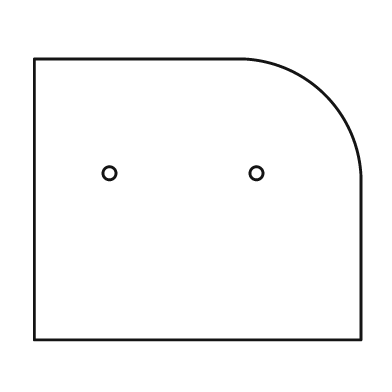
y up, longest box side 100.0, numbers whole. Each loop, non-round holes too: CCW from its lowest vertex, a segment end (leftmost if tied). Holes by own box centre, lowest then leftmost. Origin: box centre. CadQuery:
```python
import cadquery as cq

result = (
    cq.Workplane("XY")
    .moveTo(-50.0, -43.0)
    .lineTo(50.0, -43.0)
    .lineTo(50.0, 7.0)
    .threePointArc((39.0, 32.0), (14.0, 43.0))
    .lineTo(-50.0, 43.0)
    .close()
    .moveTo(-27.0, 8.0)
    .circle(2.0)
    .moveTo(18.0, 8.0)
    .circle(2.0)
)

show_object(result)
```